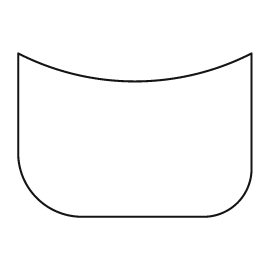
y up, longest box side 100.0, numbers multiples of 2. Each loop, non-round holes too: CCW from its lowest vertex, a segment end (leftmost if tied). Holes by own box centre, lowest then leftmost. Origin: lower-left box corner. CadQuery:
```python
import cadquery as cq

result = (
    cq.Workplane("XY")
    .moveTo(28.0, 0.0)
    .lineTo(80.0, 0.0)
    .threePointArc((94.0, 6.0), (100.0, 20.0))
    .lineTo(100.0, 70.0)
    .threePointArc((50.0, 58.0), (0.0, 70.0))
    .lineTo(0.0, 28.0)
    .threePointArc((8.0, 8.0), (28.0, 0.0))
    .close()
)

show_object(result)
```